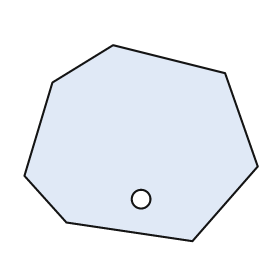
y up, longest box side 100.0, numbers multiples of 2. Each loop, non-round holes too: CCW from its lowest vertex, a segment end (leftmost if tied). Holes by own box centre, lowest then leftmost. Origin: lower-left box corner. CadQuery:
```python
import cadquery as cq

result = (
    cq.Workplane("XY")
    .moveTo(72.0, 0.0)
    .lineTo(100.0, 32.0)
    .lineTo(86.0, 72.0)
    .lineTo(38.0, 84.0)
    .lineTo(12.0, 68.0)
    .lineTo(0.0, 28.0)
    .lineTo(18.0, 8.0)
    .close()
    .moveTo(50.0, 18.0)
    .circle(4.0)
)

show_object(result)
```